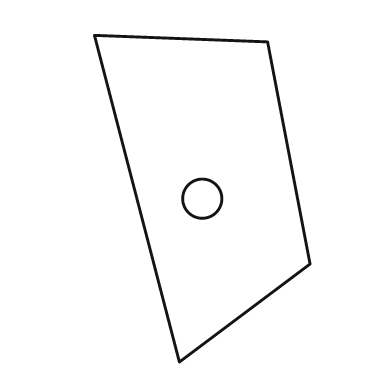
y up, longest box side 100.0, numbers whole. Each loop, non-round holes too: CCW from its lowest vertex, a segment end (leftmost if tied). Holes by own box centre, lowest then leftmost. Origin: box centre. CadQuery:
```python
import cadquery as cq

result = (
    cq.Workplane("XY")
    .moveTo(-7.0, -50.0)
    .lineTo(33.0, -20.0)
    .lineTo(20.0, 48.0)
    .lineTo(-33.0, 50.0)
    .close()
    .moveTo(0.0, 0.0)
    .circle(6.0)
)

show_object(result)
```